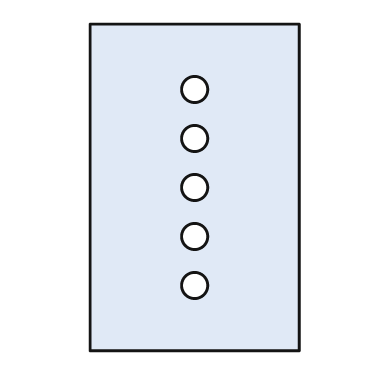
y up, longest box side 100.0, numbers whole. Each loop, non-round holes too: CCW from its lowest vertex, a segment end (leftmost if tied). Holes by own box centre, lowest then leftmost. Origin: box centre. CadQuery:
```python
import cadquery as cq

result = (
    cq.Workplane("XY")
    .moveTo(-32.0, -50.0)
    .lineTo(32.0, -50.0)
    .lineTo(32.0, 50.0)
    .lineTo(-32.0, 50.0)
    .close()
    .moveTo(0.0, -30.0)
    .circle(4.0)
    .moveTo(0.0, -15.0)
    .circle(4.0)
    .moveTo(0.0, 0.0)
    .circle(4.0)
    .moveTo(0.0, 15.0)
    .circle(4.0)
    .moveTo(0.0, 30.0)
    .circle(4.0)
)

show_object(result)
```